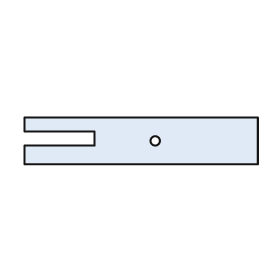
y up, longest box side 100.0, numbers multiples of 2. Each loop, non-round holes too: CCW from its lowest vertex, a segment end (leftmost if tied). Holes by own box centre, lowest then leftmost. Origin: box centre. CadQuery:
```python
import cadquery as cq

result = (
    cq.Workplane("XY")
    .moveTo(-50.0, -10.0)
    .lineTo(50.0, -10.0)
    .lineTo(50.0, 10.0)
    .lineTo(-50.0, 10.0)
    .lineTo(-50.0, 4.0)
    .lineTo(-20.0, 4.0)
    .lineTo(-20.0, -2.0)
    .lineTo(-50.0, -2.0)
    .close()
    .moveTo(6.0, 0.0)
    .circle(2.0)
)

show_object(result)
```